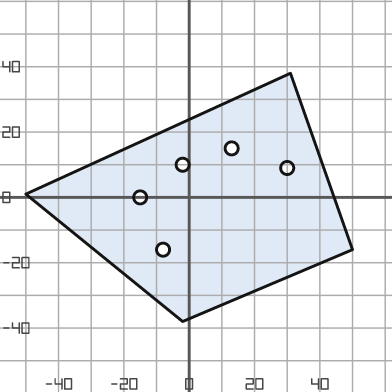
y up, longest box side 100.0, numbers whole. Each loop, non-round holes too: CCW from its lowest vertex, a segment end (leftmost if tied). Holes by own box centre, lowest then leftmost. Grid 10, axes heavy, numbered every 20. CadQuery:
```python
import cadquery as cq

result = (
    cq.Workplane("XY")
    .moveTo(-2.0, -38.0)
    .lineTo(50.0, -16.0)
    .lineTo(31.0, 38.0)
    .lineTo(-50.0, 1.0)
    .close()
    .moveTo(-8.0, -16.0)
    .circle(2.0)
    .moveTo(-15.0, 0.0)
    .circle(2.0)
    .moveTo(30.0, 9.0)
    .circle(2.0)
    .moveTo(-2.0, 10.0)
    .circle(2.0)
    .moveTo(13.0, 15.0)
    .circle(2.0)
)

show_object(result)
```